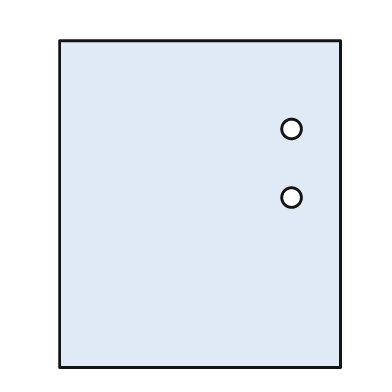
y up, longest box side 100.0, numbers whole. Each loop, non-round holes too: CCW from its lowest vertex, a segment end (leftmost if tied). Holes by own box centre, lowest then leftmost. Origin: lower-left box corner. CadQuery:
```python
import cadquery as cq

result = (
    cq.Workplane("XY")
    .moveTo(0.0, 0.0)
    .lineTo(86.0, 0.0)
    .lineTo(86.0, 100.0)
    .lineTo(0.0, 100.0)
    .close()
    .moveTo(71.0, 52.0)
    .circle(3.0)
    .moveTo(71.0, 73.0)
    .circle(3.0)
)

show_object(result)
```